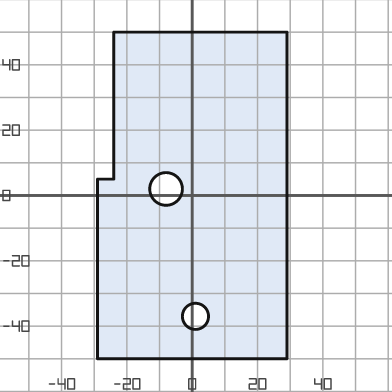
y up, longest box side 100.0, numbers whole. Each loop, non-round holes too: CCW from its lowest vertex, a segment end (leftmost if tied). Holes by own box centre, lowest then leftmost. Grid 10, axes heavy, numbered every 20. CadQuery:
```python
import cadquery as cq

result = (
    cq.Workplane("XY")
    .moveTo(-29.0, -50.0)
    .lineTo(29.0, -50.0)
    .lineTo(29.0, 50.0)
    .lineTo(-24.0, 50.0)
    .lineTo(-24.0, 5.0)
    .lineTo(-29.0, 5.0)
    .close()
    .moveTo(1.0, -37.0)
    .circle(4.0)
    .moveTo(-8.0, 2.0)
    .circle(5.0)
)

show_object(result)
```